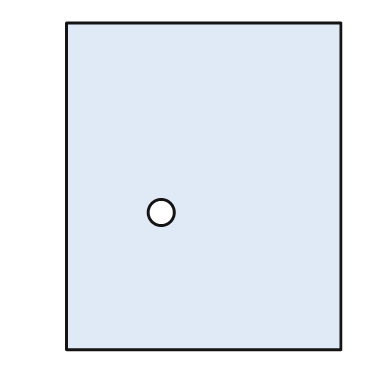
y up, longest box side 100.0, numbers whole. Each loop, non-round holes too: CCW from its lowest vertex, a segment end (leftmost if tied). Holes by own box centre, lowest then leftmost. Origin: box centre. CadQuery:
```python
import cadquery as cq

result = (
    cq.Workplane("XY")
    .moveTo(-42.0, -50.0)
    .lineTo(42.0, -50.0)
    .lineTo(42.0, 50.0)
    .lineTo(-42.0, 50.0)
    .close()
    .moveTo(-13.0, -8.0)
    .circle(4.0)
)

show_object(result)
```